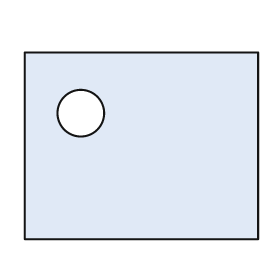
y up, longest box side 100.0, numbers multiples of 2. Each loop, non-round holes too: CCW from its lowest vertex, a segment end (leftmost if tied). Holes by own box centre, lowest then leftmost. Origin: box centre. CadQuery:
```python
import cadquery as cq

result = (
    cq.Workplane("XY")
    .moveTo(-50.0, -40.0)
    .lineTo(50.0, -40.0)
    .lineTo(50.0, 40.0)
    .lineTo(-50.0, 40.0)
    .close()
    .moveTo(-26.0, 14.0)
    .circle(10.0)
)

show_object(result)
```